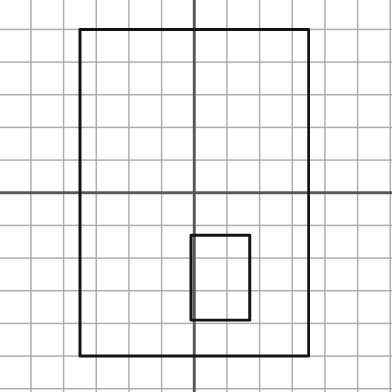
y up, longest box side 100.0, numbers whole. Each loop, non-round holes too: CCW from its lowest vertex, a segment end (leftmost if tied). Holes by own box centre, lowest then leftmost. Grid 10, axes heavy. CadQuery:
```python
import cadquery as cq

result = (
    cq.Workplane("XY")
    .moveTo(-35.0, -50.0)
    .lineTo(35.0, -50.0)
    .lineTo(35.0, 50.0)
    .lineTo(-35.0, 50.0)
    .close()
    .moveTo(-1.0, -39.0)
    .lineTo(17.0, -39.0)
    .lineTo(17.0, -13.0)
    .lineTo(-1.0, -13.0)
    .close()
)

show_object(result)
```